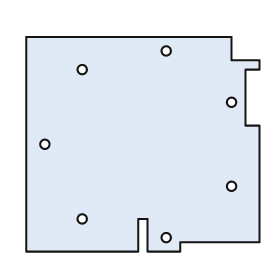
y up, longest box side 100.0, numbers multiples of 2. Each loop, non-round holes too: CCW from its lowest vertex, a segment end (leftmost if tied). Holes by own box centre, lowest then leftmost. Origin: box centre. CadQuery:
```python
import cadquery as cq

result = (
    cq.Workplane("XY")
    .moveTo(-50.0, -46.0)
    .lineTo(-2.0, -46.0)
    .lineTo(-2.0, -32.0)
    .lineTo(2.0, -32.0)
    .lineTo(2.0, -46.0)
    .lineTo(16.0, -46.0)
    .lineTo(16.0, -42.0)
    .lineTo(50.0, -42.0)
    .lineTo(50.0, 8.0)
    .lineTo(44.0, 8.0)
    .lineTo(44.0, 32.0)
    .lineTo(50.0, 32.0)
    .lineTo(50.0, 36.0)
    .lineTo(38.0, 36.0)
    .lineTo(38.0, 46.0)
    .lineTo(-50.0, 46.0)
    .close()
    .moveTo(10.0, -40.0)
    .circle(2.0)
    .moveTo(-26.0, -32.0)
    .circle(2.0)
    .moveTo(38.0, -18.0)
    .circle(2.0)
    .moveTo(-42.0, 0.0)
    .circle(2.0)
    .moveTo(38.0, 18.0)
    .circle(2.0)
    .moveTo(-26.0, 32.0)
    .circle(2.0)
    .moveTo(10.0, 40.0)
    .circle(2.0)
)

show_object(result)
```